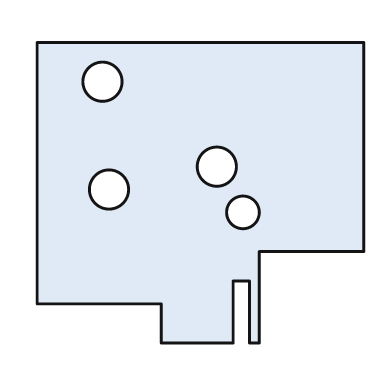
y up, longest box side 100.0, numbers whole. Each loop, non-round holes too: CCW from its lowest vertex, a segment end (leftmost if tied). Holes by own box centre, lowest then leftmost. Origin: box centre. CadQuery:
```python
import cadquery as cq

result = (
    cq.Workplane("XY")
    .moveTo(-12.0, -46.0)
    .lineTo(10.0, -46.0)
    .lineTo(10.0, -27.0)
    .lineTo(15.0, -27.0)
    .lineTo(15.0, -46.0)
    .lineTo(18.0, -46.0)
    .lineTo(18.0, -18.0)
    .lineTo(50.0, -18.0)
    .lineTo(50.0, 46.0)
    .lineTo(-50.0, 46.0)
    .lineTo(-50.0, -34.0)
    .lineTo(-12.0, -34.0)
    .close()
    .moveTo(13.0, -6.0)
    .circle(5.0)
    .moveTo(-28.0, 1.0)
    .circle(6.0)
    .moveTo(5.0, 8.0)
    .circle(6.0)
    .moveTo(-30.0, 34.0)
    .circle(6.0)
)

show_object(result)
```